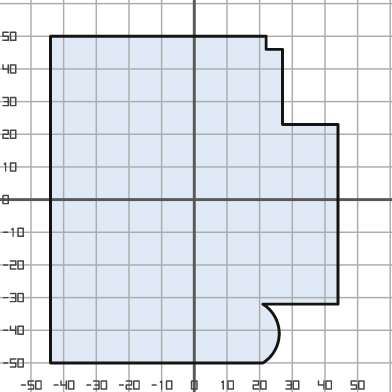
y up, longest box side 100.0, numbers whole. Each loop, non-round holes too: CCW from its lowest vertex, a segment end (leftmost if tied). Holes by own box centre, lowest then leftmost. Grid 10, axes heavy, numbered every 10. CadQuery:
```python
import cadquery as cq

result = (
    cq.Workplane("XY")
    .moveTo(-44.0, -50.0)
    .lineTo(21.0, -50.0)
    .threePointArc((26.0, -41.0), (21.0, -32.0))
    .lineTo(44.0, -32.0)
    .lineTo(44.0, 23.0)
    .lineTo(27.0, 23.0)
    .lineTo(27.0, 46.0)
    .lineTo(22.0, 46.0)
    .lineTo(22.0, 50.0)
    .lineTo(-44.0, 50.0)
    .close()
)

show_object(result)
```